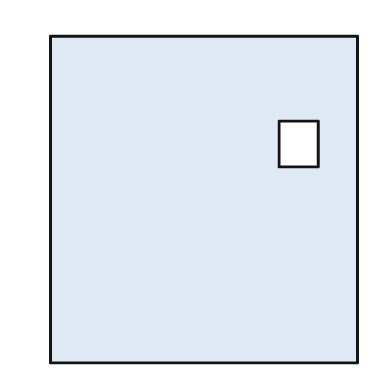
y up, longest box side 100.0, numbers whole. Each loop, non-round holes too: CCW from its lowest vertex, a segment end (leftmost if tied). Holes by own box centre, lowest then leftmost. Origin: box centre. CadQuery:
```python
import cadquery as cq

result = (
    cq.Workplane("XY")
    .moveTo(-47.0, -50.0)
    .lineTo(47.0, -50.0)
    .lineTo(47.0, 50.0)
    .lineTo(-47.0, 50.0)
    .close()
    .moveTo(23.0, 10.0)
    .lineTo(35.0, 10.0)
    .lineTo(35.0, 24.0)
    .lineTo(23.0, 24.0)
    .close()
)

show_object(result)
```